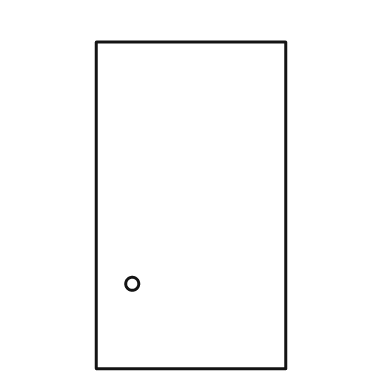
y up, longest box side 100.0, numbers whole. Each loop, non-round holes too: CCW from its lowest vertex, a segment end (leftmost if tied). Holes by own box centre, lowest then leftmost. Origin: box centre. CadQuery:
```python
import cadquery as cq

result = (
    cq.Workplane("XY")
    .moveTo(-29.0, -50.0)
    .lineTo(29.0, -50.0)
    .lineTo(29.0, 50.0)
    .lineTo(-29.0, 50.0)
    .close()
    .moveTo(-18.0, -24.0)
    .circle(2.0)
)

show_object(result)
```